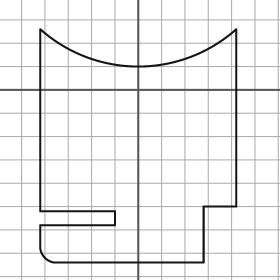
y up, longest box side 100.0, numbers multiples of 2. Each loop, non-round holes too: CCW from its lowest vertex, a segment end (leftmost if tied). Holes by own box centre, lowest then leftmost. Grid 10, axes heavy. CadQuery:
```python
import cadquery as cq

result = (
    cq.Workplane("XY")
    .moveTo(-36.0, -74.0)
    .lineTo(28.0, -74.0)
    .lineTo(28.0, -50.0)
    .lineTo(42.0, -50.0)
    .lineTo(42.0, 26.0)
    .threePointArc((0.0, 10.0), (-42.0, 26.0))
    .lineTo(-42.0, -52.0)
    .lineTo(-10.0, -52.0)
    .lineTo(-10.0, -58.0)
    .lineTo(-42.0, -58.0)
    .lineTo(-42.0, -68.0)
    .threePointArc((-40.0, -72.0), (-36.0, -74.0))
    .close()
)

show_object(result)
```